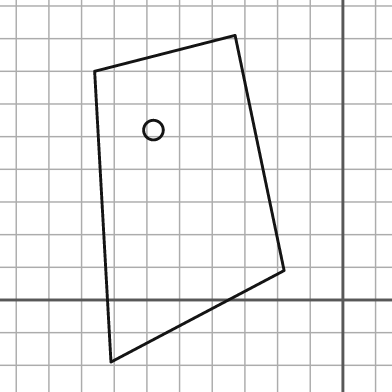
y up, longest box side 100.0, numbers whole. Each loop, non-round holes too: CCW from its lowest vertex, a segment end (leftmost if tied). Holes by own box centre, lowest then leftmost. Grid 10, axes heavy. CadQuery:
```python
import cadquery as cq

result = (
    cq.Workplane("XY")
    .moveTo(-71.0, -19.0)
    .lineTo(-18.0, 9.0)
    .lineTo(-33.0, 81.0)
    .lineTo(-76.0, 70.0)
    .close()
    .moveTo(-58.0, 52.0)
    .circle(3.0)
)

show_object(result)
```